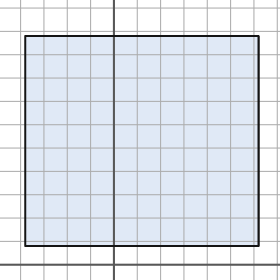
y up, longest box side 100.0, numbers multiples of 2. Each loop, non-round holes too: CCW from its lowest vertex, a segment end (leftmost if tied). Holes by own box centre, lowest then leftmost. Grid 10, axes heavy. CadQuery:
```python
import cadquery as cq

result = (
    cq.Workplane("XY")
    .moveTo(-38.0, 8.0)
    .lineTo(62.0, 8.0)
    .lineTo(62.0, 98.0)
    .lineTo(-38.0, 98.0)
    .close()
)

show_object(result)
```